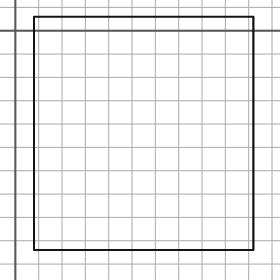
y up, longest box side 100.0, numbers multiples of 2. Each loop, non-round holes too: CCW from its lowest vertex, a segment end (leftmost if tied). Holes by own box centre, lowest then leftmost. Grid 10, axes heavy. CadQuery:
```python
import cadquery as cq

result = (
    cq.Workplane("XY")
    .moveTo(8.0, -94.0)
    .lineTo(102.0, -94.0)
    .lineTo(102.0, 6.0)
    .lineTo(8.0, 6.0)
    .close()
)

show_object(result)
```